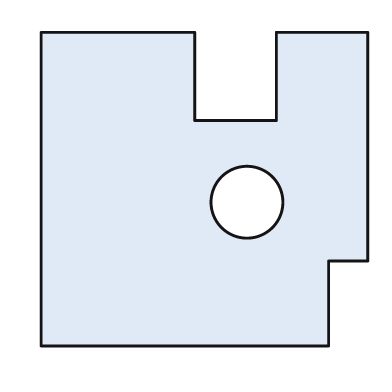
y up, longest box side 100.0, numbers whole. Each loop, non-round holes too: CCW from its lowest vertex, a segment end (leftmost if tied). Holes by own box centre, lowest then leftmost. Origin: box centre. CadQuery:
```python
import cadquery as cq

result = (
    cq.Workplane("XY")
    .moveTo(-50.0, -48.0)
    .lineTo(38.0, -48.0)
    .lineTo(38.0, -22.0)
    .lineTo(50.0, -22.0)
    .lineTo(50.0, 48.0)
    .lineTo(22.0, 48.0)
    .lineTo(22.0, 21.0)
    .lineTo(-3.0, 21.0)
    .lineTo(-3.0, 48.0)
    .lineTo(-50.0, 48.0)
    .close()
    .moveTo(13.0, -4.0)
    .circle(11.0)
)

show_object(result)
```